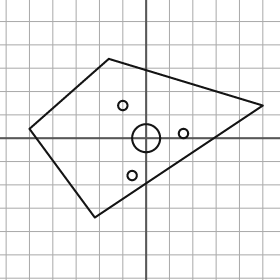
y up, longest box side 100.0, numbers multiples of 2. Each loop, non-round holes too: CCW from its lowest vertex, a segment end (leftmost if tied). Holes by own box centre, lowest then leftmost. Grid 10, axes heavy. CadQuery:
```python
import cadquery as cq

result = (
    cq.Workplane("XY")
    .moveTo(-22.0, -34.0)
    .lineTo(50.0, 14.0)
    .lineTo(-16.0, 34.0)
    .lineTo(-50.0, 4.0)
    .close()
    .moveTo(-6.0, -16.0)
    .circle(2.0)
    .moveTo(0.0, 0.0)
    .circle(6.0)
    .moveTo(16.0, 2.0)
    .circle(2.0)
    .moveTo(-10.0, 14.0)
    .circle(2.0)
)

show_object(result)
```